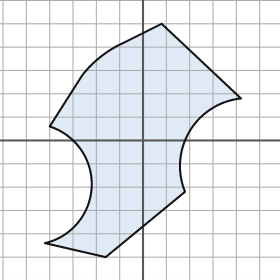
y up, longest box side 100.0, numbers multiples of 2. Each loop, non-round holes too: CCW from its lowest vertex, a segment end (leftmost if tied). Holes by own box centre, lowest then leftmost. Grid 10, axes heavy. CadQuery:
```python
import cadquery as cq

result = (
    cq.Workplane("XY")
    .moveTo(-16.0, -50.0)
    .lineTo(18.0, -22.0)
    .threePointArc((20.0, 4.0), (42.0, 18.0))
    .lineTo(8.0, 50.0)
    .lineTo(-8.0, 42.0)
    .threePointArc((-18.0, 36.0), (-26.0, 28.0))
    .lineTo(-40.0, 6.0)
    .threePointArc((-22.0, -20.0), (-42.0, -44.0))
    .close()
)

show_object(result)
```